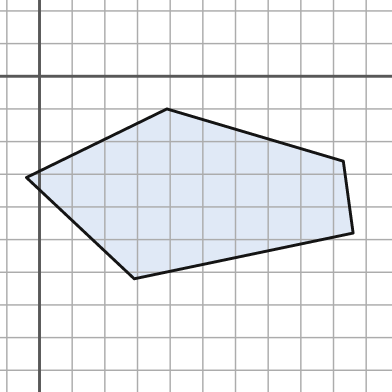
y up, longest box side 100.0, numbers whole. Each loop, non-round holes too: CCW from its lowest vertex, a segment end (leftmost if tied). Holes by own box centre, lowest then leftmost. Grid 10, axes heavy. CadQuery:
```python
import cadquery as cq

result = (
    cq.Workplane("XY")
    .moveTo(29.0, -62.0)
    .lineTo(96.0, -48.0)
    .lineTo(93.0, -26.0)
    .lineTo(39.0, -10.0)
    .lineTo(-4.0, -31.0)
    .close()
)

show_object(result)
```